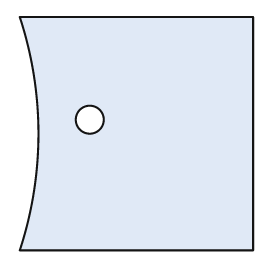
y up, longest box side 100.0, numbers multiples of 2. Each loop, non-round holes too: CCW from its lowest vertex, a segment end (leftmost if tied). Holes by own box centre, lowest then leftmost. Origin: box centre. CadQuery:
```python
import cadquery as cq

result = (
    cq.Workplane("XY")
    .moveTo(-50.0, -50.0)
    .lineTo(50.0, -50.0)
    .lineTo(50.0, 50.0)
    .lineTo(-50.0, 50.0)
    .threePointArc((-42.0, 0.0), (-50.0, -50.0))
    .close()
    .moveTo(-20.0, 6.0)
    .circle(6.0)
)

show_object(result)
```